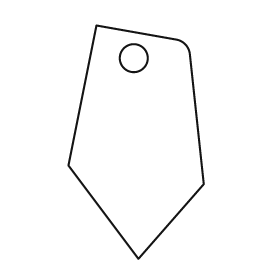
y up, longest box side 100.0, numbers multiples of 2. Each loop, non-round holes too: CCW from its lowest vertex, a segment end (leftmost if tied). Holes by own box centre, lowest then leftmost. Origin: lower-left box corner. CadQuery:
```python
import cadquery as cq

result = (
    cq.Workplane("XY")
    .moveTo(30.0, 0.0)
    .lineTo(58.0, 32.0)
    .lineTo(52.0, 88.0)
    .threePointArc((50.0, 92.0), (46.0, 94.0))
    .lineTo(12.0, 100.0)
    .lineTo(0.0, 40.0)
    .close()
    .moveTo(28.0, 86.0)
    .circle(6.0)
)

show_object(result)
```